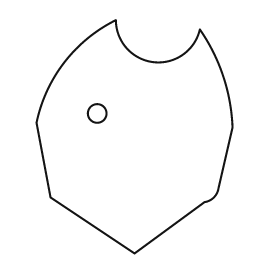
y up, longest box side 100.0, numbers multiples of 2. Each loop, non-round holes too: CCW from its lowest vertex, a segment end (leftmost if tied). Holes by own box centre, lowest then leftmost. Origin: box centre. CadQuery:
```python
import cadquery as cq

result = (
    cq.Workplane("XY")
    .moveTo(0.0, -50.0)
    .lineTo(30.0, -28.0)
    .threePointArc((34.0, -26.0), (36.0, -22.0))
    .lineTo(42.0, 4.0)
    .threePointArc((38.0, 26.0), (28.0, 46.0))
    .threePointArc((8.0, 32.0), (-8.0, 50.0))
    .threePointArc((-30.0, 32.0), (-42.0, 6.0))
    .lineTo(-36.0, -26.0)
    .close()
    .moveTo(-16.0, 10.0)
    .circle(4.0)
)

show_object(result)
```